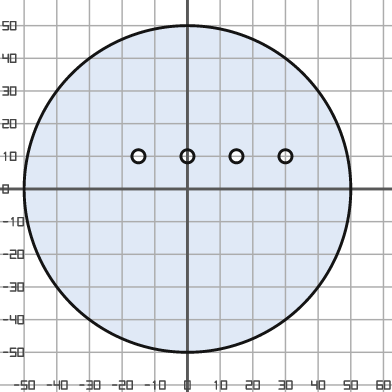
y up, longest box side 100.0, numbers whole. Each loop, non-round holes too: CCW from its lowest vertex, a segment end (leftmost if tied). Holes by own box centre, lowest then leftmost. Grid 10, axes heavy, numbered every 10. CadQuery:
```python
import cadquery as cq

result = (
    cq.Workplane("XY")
    .moveTo(0.0, 0.0)
    .circle(50.0)
    .moveTo(-15.0, 10.0)
    .circle(2.0)
    .moveTo(0.0, 10.0)
    .circle(2.0)
    .moveTo(15.0, 10.0)
    .circle(2.0)
    .moveTo(30.0, 10.0)
    .circle(2.0)
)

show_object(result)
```